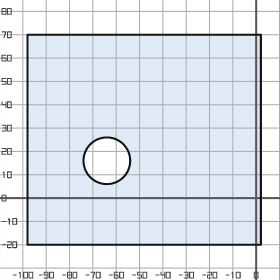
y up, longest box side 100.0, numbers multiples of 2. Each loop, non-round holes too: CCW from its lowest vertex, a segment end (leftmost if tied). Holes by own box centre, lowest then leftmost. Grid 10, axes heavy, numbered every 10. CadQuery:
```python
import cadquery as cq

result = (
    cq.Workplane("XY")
    .moveTo(-98.0, -20.0)
    .lineTo(2.0, -20.0)
    .lineTo(2.0, 70.0)
    .lineTo(-98.0, 70.0)
    .close()
    .moveTo(-64.0, 16.0)
    .circle(10.0)
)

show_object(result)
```